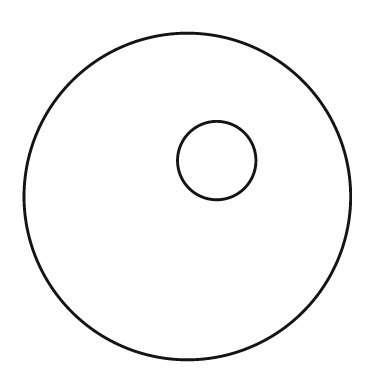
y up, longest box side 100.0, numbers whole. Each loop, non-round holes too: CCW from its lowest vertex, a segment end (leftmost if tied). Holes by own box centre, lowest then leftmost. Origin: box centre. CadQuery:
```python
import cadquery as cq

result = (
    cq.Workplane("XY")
    .moveTo(0.0, 0.0)
    .circle(50.0)
    .moveTo(9.0, 11.0)
    .circle(12.0)
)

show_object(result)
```